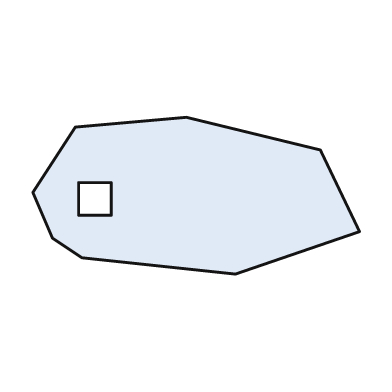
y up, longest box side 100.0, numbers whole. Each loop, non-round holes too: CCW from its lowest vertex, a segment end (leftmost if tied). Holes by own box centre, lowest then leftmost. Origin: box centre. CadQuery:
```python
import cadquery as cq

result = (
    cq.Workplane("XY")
    .moveTo(12.0, -24.0)
    .lineTo(50.0, -11.0)
    .lineTo(38.0, 14.0)
    .lineTo(-3.0, 24.0)
    .lineTo(-37.0, 21.0)
    .lineTo(-50.0, 1.0)
    .lineTo(-44.0, -13.0)
    .lineTo(-35.0, -19.0)
    .close()
    .moveTo(-36.0, -6.0)
    .lineTo(-26.0, -6.0)
    .lineTo(-26.0, 4.0)
    .lineTo(-36.0, 4.0)
    .close()
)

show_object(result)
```